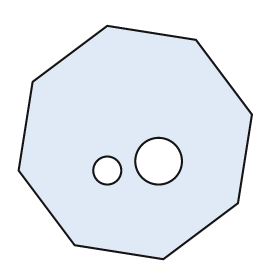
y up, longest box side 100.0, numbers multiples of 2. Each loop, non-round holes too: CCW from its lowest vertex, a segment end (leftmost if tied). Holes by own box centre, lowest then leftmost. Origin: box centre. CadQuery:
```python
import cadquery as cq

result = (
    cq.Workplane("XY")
    .moveTo(12.0, -50.0)
    .lineTo(44.0, -26.0)
    .lineTo(50.0, 12.0)
    .lineTo(26.0, 44.0)
    .lineTo(-12.0, 50.0)
    .lineTo(-44.0, 26.0)
    .lineTo(-50.0, -12.0)
    .lineTo(-26.0, -44.0)
    .close()
    .moveTo(-12.0, -12.0)
    .circle(6.0)
    .moveTo(10.0, -8.0)
    .circle(10.0)
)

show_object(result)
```